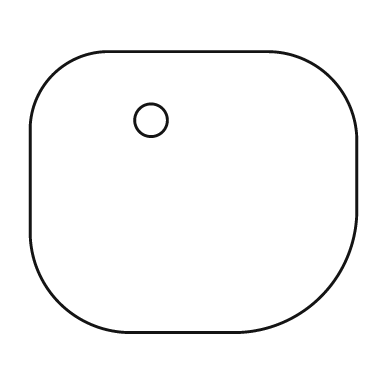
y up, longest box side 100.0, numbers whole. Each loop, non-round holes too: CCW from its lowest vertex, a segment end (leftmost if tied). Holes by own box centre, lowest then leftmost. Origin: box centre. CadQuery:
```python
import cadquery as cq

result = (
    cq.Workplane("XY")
    .moveTo(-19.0, -43.0)
    .lineTo(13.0, -43.0)
    .threePointArc((39.0, -32.0), (50.0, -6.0))
    .lineTo(50.0, 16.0)
    .threePointArc((42.0, 35.0), (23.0, 43.0))
    .lineTo(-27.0, 43.0)
    .threePointArc((-43.0, 36.0), (-50.0, 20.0))
    .lineTo(-50.0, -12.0)
    .threePointArc((-41.0, -34.0), (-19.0, -43.0))
    .close()
    .moveTo(-13.0, 22.0)
    .circle(5.0)
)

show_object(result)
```